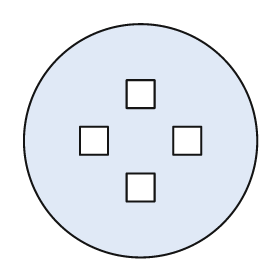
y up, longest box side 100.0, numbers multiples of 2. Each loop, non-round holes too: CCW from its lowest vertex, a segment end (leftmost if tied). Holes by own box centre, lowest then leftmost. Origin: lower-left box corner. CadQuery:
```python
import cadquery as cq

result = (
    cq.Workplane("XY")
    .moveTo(50.0, 50.0)
    .circle(50.0)
    .moveTo(44.0, 24.0)
    .lineTo(56.0, 24.0)
    .lineTo(56.0, 36.0)
    .lineTo(44.0, 36.0)
    .close()
    .moveTo(24.0, 44.0)
    .lineTo(36.0, 44.0)
    .lineTo(36.0, 56.0)
    .lineTo(24.0, 56.0)
    .close()
    .moveTo(64.0, 44.0)
    .lineTo(76.0, 44.0)
    .lineTo(76.0, 56.0)
    .lineTo(64.0, 56.0)
    .close()
    .moveTo(44.0, 64.0)
    .lineTo(56.0, 64.0)
    .lineTo(56.0, 76.0)
    .lineTo(44.0, 76.0)
    .close()
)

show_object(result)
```